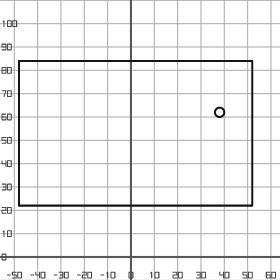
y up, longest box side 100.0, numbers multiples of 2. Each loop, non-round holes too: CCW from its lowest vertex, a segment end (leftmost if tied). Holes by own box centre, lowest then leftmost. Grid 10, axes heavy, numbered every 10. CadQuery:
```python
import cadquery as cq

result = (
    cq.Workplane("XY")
    .moveTo(-48.0, 22.0)
    .lineTo(52.0, 22.0)
    .lineTo(52.0, 84.0)
    .lineTo(-48.0, 84.0)
    .close()
    .moveTo(38.0, 62.0)
    .circle(2.0)
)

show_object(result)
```